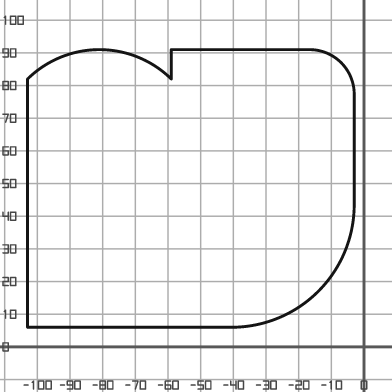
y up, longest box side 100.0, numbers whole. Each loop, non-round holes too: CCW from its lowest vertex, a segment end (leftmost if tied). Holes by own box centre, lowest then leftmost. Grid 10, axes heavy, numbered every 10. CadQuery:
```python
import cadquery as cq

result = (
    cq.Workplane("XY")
    .moveTo(-103.0, 6.0)
    .lineTo(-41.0, 6.0)
    .threePointArc((-14.0, 17.0), (-3.0, 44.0))
    .lineTo(-3.0, 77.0)
    .threePointArc((-7.0, 87.0), (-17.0, 91.0))
    .lineTo(-59.0, 91.0)
    .lineTo(-59.0, 82.0)
    .threePointArc((-81.0, 91.0), (-103.0, 82.0))
    .close()
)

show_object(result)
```